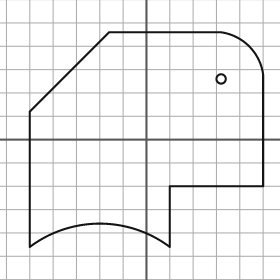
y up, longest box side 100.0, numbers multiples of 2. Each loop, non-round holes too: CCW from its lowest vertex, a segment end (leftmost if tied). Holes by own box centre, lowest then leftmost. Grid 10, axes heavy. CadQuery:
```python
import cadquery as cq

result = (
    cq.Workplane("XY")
    .moveTo(-50.0, -46.0)
    .threePointArc((-20.0, -36.0), (10.0, -46.0))
    .lineTo(10.0, -20.0)
    .lineTo(50.0, -20.0)
    .lineTo(50.0, 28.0)
    .threePointArc((44.0, 40.0), (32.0, 46.0))
    .lineTo(-16.0, 46.0)
    .lineTo(-50.0, 12.0)
    .close()
    .moveTo(32.0, 26.0)
    .circle(2.0)
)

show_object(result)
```